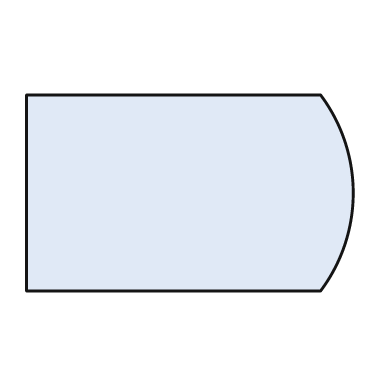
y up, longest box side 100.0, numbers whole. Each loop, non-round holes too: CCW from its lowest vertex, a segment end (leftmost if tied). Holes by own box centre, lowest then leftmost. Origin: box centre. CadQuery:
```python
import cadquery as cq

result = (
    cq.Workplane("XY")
    .moveTo(-50.0, -30.0)
    .lineTo(40.0, -30.0)
    .threePointArc((50.0, 0.0), (40.0, 30.0))
    .lineTo(-50.0, 30.0)
    .close()
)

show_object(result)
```